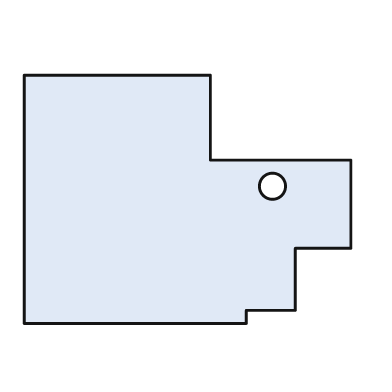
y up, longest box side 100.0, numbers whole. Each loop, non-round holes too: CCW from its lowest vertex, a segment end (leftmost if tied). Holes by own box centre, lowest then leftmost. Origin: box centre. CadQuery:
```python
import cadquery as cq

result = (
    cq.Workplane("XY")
    .moveTo(-50.0, -38.0)
    .lineTo(18.0, -38.0)
    .lineTo(18.0, -34.0)
    .lineTo(33.0, -34.0)
    .lineTo(33.0, -15.0)
    .lineTo(50.0, -15.0)
    .lineTo(50.0, 12.0)
    .lineTo(7.0, 12.0)
    .lineTo(7.0, 38.0)
    .lineTo(-50.0, 38.0)
    .close()
    .moveTo(26.0, 4.0)
    .circle(4.0)
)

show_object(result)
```